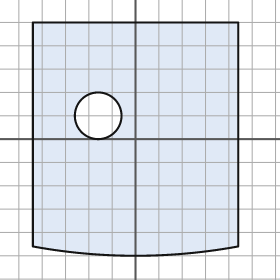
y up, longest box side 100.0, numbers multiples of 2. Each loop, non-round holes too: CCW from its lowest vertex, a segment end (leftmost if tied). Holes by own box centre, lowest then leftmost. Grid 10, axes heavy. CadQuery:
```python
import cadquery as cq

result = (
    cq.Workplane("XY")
    .moveTo(-44.0, -46.0)
    .threePointArc((0.0, -50.0), (44.0, -46.0))
    .lineTo(44.0, 50.0)
    .lineTo(-44.0, 50.0)
    .close()
    .moveTo(-16.0, 10.0)
    .circle(10.0)
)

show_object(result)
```